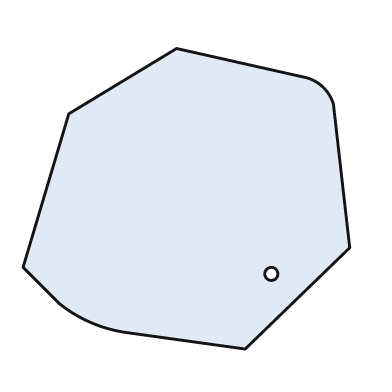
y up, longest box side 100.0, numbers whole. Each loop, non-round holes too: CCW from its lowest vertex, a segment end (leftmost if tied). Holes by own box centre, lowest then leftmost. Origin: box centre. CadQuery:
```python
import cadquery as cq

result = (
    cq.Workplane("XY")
    .moveTo(18.0, -46.0)
    .lineTo(50.0, -15.0)
    .lineTo(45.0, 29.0)
    .threePointArc((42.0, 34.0), (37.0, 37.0))
    .lineTo(-3.0, 46.0)
    .lineTo(-36.0, 26.0)
    .lineTo(-50.0, -21.0)
    .lineTo(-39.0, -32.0)
    .threePointArc((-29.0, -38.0), (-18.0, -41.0))
    .close()
    .moveTo(26.0, -23.0)
    .circle(2.0)
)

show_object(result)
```